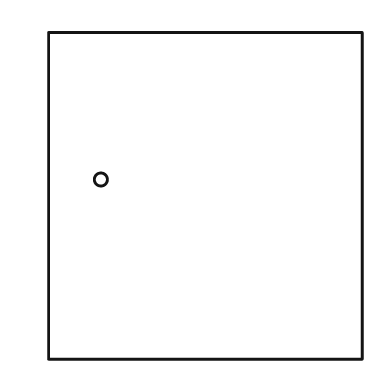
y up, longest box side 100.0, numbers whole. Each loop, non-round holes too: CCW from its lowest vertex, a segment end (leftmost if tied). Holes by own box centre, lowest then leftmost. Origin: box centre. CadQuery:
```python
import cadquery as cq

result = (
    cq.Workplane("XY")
    .moveTo(-48.0, -50.0)
    .lineTo(48.0, -50.0)
    .lineTo(48.0, 50.0)
    .lineTo(-48.0, 50.0)
    .close()
    .moveTo(-32.0, 5.0)
    .circle(2.0)
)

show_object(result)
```